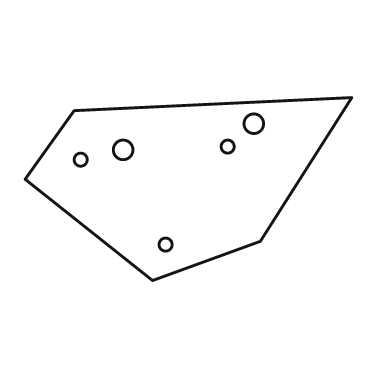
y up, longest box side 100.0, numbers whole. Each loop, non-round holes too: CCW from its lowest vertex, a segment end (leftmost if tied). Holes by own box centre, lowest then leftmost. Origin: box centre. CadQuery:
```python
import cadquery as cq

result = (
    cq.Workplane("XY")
    .moveTo(-11.0, -28.0)
    .lineTo(22.0, -16.0)
    .lineTo(50.0, 28.0)
    .lineTo(-35.0, 24.0)
    .lineTo(-50.0, 3.0)
    .close()
    .moveTo(-7.0, -17.0)
    .circle(2.0)
    .moveTo(-33.0, 9.0)
    .circle(2.0)
    .moveTo(-20.0, 12.0)
    .circle(3.0)
    .moveTo(12.0, 13.0)
    .circle(2.0)
    .moveTo(20.0, 20.0)
    .circle(3.0)
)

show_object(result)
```